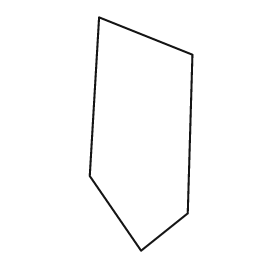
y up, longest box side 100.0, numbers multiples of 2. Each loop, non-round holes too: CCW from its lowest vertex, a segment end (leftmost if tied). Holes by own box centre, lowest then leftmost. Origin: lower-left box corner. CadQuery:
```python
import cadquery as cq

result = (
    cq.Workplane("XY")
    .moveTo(22.0, 0.0)
    .lineTo(42.0, 16.0)
    .lineTo(44.0, 84.0)
    .lineTo(4.0, 100.0)
    .lineTo(0.0, 32.0)
    .close()
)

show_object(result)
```